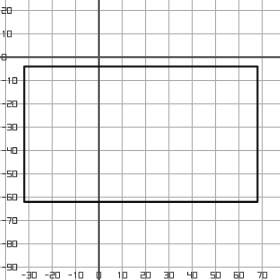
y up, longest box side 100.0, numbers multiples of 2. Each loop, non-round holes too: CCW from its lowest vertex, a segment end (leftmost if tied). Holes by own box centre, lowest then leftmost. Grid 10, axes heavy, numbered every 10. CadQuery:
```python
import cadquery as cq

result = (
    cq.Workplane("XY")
    .moveTo(-32.0, -62.0)
    .lineTo(68.0, -62.0)
    .lineTo(68.0, -4.0)
    .lineTo(-32.0, -4.0)
    .close()
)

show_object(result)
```